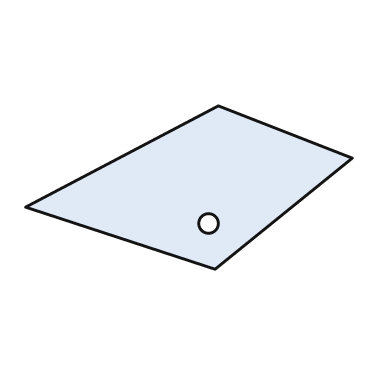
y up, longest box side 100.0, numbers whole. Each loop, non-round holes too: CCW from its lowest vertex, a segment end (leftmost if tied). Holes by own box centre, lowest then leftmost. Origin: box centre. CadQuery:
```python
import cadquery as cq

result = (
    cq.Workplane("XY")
    .moveTo(8.0, -25.0)
    .lineTo(50.0, 9.0)
    .lineTo(9.0, 25.0)
    .lineTo(-50.0, -6.0)
    .close()
    .moveTo(6.0, -11.0)
    .circle(3.0)
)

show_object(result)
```